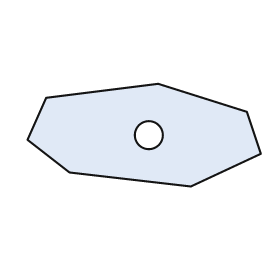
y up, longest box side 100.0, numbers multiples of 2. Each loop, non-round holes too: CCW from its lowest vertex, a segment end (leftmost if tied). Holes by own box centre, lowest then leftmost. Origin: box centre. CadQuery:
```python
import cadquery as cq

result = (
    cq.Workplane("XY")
    .moveTo(20.0, -22.0)
    .lineTo(50.0, -8.0)
    .lineTo(44.0, 10.0)
    .lineTo(6.0, 22.0)
    .lineTo(-42.0, 16.0)
    .lineTo(-50.0, -2.0)
    .lineTo(-32.0, -16.0)
    .close()
    .moveTo(2.0, 0.0)
    .circle(6.0)
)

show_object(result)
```